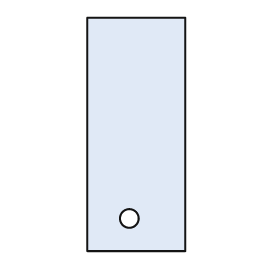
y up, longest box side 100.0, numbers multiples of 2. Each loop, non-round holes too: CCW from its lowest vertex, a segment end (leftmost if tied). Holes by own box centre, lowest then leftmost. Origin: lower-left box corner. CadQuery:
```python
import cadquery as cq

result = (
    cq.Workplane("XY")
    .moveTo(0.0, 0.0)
    .lineTo(42.0, 0.0)
    .lineTo(42.0, 100.0)
    .lineTo(0.0, 100.0)
    .close()
    .moveTo(18.0, 14.0)
    .circle(4.0)
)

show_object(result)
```